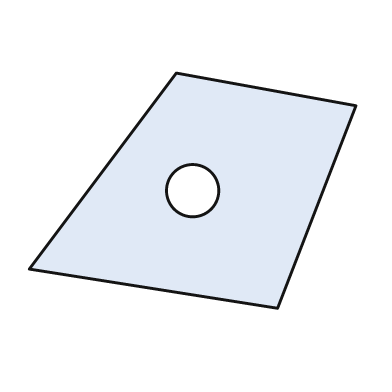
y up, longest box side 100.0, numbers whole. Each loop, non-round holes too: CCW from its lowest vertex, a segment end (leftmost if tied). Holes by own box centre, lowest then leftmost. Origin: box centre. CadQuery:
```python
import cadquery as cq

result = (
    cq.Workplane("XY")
    .moveTo(26.0, -36.0)
    .lineTo(50.0, 26.0)
    .lineTo(-5.0, 36.0)
    .lineTo(-50.0, -24.0)
    .close()
    .moveTo(0.0, 0.0)
    .circle(8.0)
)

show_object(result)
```